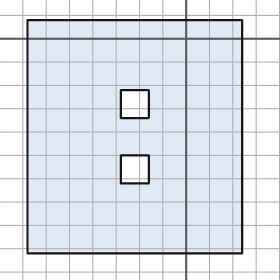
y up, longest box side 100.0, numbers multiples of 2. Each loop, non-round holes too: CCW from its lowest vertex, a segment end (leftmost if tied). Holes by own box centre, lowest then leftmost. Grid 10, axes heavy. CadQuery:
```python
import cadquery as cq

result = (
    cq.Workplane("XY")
    .moveTo(-68.0, -92.0)
    .lineTo(24.0, -92.0)
    .lineTo(24.0, 8.0)
    .lineTo(-68.0, 8.0)
    .close()
    .moveTo(-28.0, -62.0)
    .lineTo(-16.0, -62.0)
    .lineTo(-16.0, -50.0)
    .lineTo(-28.0, -50.0)
    .close()
    .moveTo(-28.0, -34.0)
    .lineTo(-16.0, -34.0)
    .lineTo(-16.0, -22.0)
    .lineTo(-28.0, -22.0)
    .close()
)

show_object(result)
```